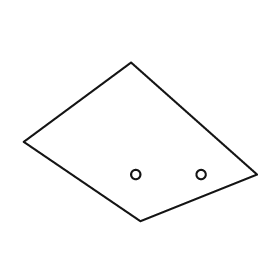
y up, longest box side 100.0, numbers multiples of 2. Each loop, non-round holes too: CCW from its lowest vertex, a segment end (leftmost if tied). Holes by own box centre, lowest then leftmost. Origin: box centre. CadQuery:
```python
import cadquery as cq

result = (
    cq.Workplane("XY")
    .moveTo(0.0, -34.0)
    .lineTo(50.0, -14.0)
    .lineTo(-4.0, 34.0)
    .lineTo(-50.0, 0.0)
    .close()
    .moveTo(-2.0, -14.0)
    .circle(2.0)
    .moveTo(26.0, -14.0)
    .circle(2.0)
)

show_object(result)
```